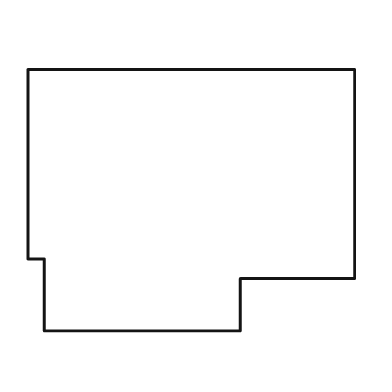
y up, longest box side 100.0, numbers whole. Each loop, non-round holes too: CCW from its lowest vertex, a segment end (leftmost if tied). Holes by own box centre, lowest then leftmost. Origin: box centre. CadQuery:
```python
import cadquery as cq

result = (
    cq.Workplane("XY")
    .moveTo(-45.0, -40.0)
    .lineTo(15.0, -40.0)
    .lineTo(15.0, -24.0)
    .lineTo(50.0, -24.0)
    .lineTo(50.0, 40.0)
    .lineTo(-50.0, 40.0)
    .lineTo(-50.0, -18.0)
    .lineTo(-45.0, -18.0)
    .close()
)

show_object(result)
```